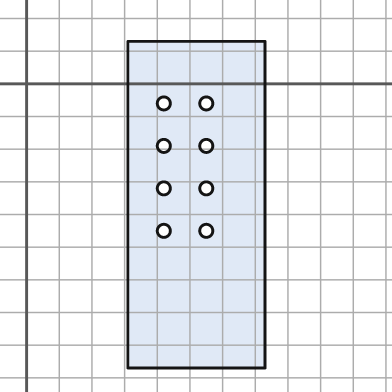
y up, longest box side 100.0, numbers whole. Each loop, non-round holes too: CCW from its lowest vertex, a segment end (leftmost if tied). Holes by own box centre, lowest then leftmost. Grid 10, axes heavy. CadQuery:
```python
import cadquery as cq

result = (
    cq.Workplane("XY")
    .moveTo(31.0, -87.0)
    .lineTo(73.0, -87.0)
    .lineTo(73.0, 13.0)
    .lineTo(31.0, 13.0)
    .close()
    .moveTo(42.0, -45.0)
    .circle(2.0)
    .moveTo(55.0, -45.0)
    .circle(2.0)
    .moveTo(42.0, -32.0)
    .circle(2.0)
    .moveTo(55.0, -32.0)
    .circle(2.0)
    .moveTo(42.0, -19.0)
    .circle(2.0)
    .moveTo(55.0, -19.0)
    .circle(2.0)
    .moveTo(42.0, -6.0)
    .circle(2.0)
    .moveTo(55.0, -6.0)
    .circle(2.0)
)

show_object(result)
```